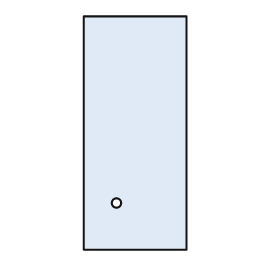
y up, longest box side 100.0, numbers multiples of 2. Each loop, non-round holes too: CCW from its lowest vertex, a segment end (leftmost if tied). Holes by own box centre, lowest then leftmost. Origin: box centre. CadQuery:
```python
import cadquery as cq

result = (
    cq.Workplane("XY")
    .moveTo(-22.0, -50.0)
    .lineTo(22.0, -50.0)
    .lineTo(22.0, 50.0)
    .lineTo(-22.0, 50.0)
    .close()
    .moveTo(-8.0, -30.0)
    .circle(2.0)
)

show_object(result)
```